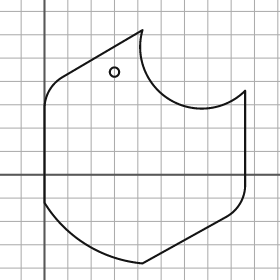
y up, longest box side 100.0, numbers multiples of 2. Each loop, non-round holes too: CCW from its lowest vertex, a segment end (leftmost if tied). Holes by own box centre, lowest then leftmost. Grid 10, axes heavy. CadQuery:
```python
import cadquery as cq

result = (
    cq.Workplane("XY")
    .moveTo(42.0, -38.0)
    .lineTo(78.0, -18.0)
    .threePointArc((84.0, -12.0), (86.0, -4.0))
    .lineTo(86.0, 36.0)
    .threePointArc((54.0, 32.0), (42.0, 62.0))
    .lineTo(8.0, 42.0)
    .threePointArc((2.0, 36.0), (0.0, 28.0))
    .lineTo(0.0, -12.0)
    .threePointArc((18.0, -30.0), (42.0, -38.0))
    .close()
    .moveTo(30.0, 44.0)
    .circle(2.0)
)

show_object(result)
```